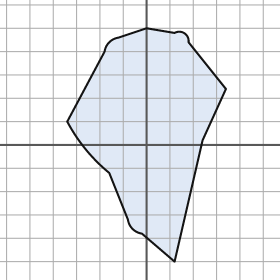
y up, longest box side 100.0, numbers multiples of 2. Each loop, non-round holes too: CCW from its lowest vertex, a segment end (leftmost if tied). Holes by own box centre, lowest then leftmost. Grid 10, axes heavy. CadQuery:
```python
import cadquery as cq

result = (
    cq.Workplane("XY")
    .moveTo(12.0, -50.0)
    .lineTo(24.0, 2.0)
    .lineTo(34.0, 24.0)
    .lineTo(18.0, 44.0)
    .threePointArc((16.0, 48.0), (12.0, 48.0))
    .lineTo(0.0, 50.0)
    .lineTo(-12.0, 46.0)
    .threePointArc((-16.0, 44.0), (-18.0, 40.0))
    .lineTo(-34.0, 10.0)
    .threePointArc((-26.0, -2.0), (-16.0, -12.0))
    .lineTo(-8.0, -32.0)
    .threePointArc((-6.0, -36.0), (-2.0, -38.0))
    .close()
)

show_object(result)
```